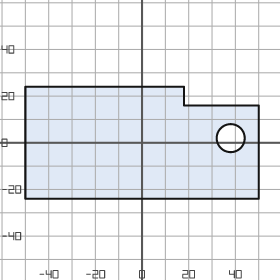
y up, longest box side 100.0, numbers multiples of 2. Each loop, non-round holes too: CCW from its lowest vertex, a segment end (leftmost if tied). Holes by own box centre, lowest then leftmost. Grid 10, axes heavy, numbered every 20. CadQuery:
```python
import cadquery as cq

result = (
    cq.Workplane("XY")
    .moveTo(-50.0, -24.0)
    .lineTo(50.0, -24.0)
    .lineTo(50.0, 16.0)
    .lineTo(18.0, 16.0)
    .lineTo(18.0, 24.0)
    .lineTo(-50.0, 24.0)
    .close()
    .moveTo(38.0, 2.0)
    .circle(6.0)
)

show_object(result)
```